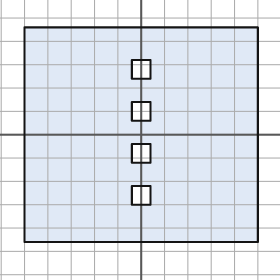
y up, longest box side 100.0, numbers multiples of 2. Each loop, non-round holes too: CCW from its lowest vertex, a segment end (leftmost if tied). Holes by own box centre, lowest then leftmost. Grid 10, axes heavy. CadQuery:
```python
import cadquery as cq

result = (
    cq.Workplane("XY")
    .moveTo(-50.0, -46.0)
    .lineTo(50.0, -46.0)
    .lineTo(50.0, 46.0)
    .lineTo(-50.0, 46.0)
    .close()
    .moveTo(-4.0, -30.0)
    .lineTo(4.0, -30.0)
    .lineTo(4.0, -22.0)
    .lineTo(-4.0, -22.0)
    .close()
    .moveTo(-4.0, -12.0)
    .lineTo(4.0, -12.0)
    .lineTo(4.0, -4.0)
    .lineTo(-4.0, -4.0)
    .close()
    .moveTo(-4.0, 6.0)
    .lineTo(4.0, 6.0)
    .lineTo(4.0, 14.0)
    .lineTo(-4.0, 14.0)
    .close()
    .moveTo(-4.0, 24.0)
    .lineTo(4.0, 24.0)
    .lineTo(4.0, 32.0)
    .lineTo(-4.0, 32.0)
    .close()
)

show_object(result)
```